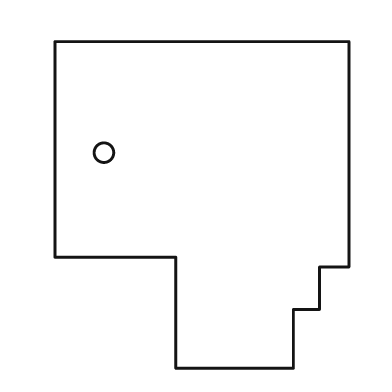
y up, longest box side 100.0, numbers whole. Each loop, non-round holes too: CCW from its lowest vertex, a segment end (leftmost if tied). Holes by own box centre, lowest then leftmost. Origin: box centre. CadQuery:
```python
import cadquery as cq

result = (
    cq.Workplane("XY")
    .moveTo(-8.0, -50.0)
    .lineTo(28.0, -50.0)
    .lineTo(28.0, -32.0)
    .lineTo(36.0, -32.0)
    .lineTo(36.0, -19.0)
    .lineTo(45.0, -19.0)
    .lineTo(45.0, 50.0)
    .lineTo(-45.0, 50.0)
    .lineTo(-45.0, -16.0)
    .lineTo(-8.0, -16.0)
    .close()
    .moveTo(-30.0, 16.0)
    .circle(3.0)
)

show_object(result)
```